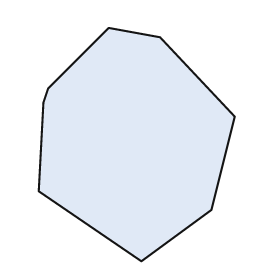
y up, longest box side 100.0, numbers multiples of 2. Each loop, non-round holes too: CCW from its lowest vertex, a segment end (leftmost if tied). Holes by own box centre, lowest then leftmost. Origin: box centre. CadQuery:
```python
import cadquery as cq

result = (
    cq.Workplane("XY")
    .moveTo(2.0, -50.0)
    .lineTo(32.0, -28.0)
    .lineTo(42.0, 12.0)
    .lineTo(10.0, 46.0)
    .lineTo(-12.0, 50.0)
    .lineTo(-38.0, 24.0)
    .lineTo(-40.0, 18.0)
    .lineTo(-42.0, -20.0)
    .close()
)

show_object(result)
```